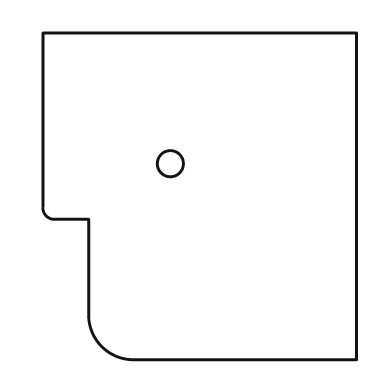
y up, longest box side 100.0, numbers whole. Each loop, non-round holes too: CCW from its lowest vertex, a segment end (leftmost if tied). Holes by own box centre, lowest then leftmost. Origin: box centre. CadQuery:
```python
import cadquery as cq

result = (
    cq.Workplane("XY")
    .moveTo(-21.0, -50.0)
    .lineTo(48.0, -50.0)
    .lineTo(48.0, 50.0)
    .lineTo(-48.0, 50.0)
    .lineTo(-48.0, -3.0)
    .threePointArc((-47.0, -6.0), (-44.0, -7.0))
    .lineTo(-34.0, -7.0)
    .lineTo(-34.0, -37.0)
    .threePointArc((-30.0, -46.0), (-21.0, -50.0))
    .close()
    .moveTo(-9.0, 10.0)
    .circle(4.0)
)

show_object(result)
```